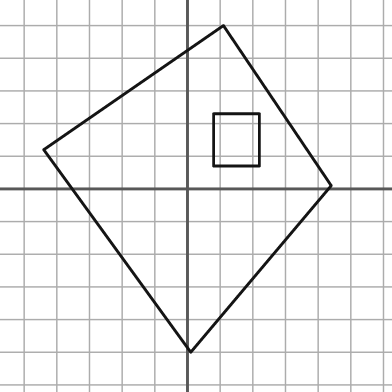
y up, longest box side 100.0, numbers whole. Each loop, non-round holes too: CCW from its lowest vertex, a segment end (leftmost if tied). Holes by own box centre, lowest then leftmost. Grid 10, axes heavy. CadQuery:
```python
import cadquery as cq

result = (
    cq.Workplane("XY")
    .moveTo(1.0, -50.0)
    .lineTo(44.0, 1.0)
    .lineTo(11.0, 50.0)
    .lineTo(-44.0, 12.0)
    .close()
    .moveTo(8.0, 7.0)
    .lineTo(22.0, 7.0)
    .lineTo(22.0, 23.0)
    .lineTo(8.0, 23.0)
    .close()
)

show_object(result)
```